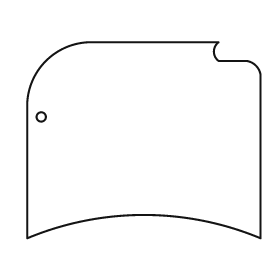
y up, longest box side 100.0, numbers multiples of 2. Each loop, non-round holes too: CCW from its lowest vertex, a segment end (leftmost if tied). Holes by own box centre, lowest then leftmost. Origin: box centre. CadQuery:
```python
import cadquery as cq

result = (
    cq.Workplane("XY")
    .moveTo(-50.0, -42.0)
    .threePointArc((0.0, -32.0), (50.0, -42.0))
    .lineTo(50.0, 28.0)
    .threePointArc((48.0, 32.0), (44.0, 34.0))
    .lineTo(32.0, 34.0)
    .threePointArc((30.0, 38.0), (32.0, 42.0))
    .lineTo(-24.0, 42.0)
    .threePointArc((-42.0, 34.0), (-50.0, 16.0))
    .close()
    .moveTo(-44.0, 10.0)
    .circle(2.0)
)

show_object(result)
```